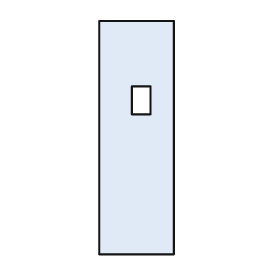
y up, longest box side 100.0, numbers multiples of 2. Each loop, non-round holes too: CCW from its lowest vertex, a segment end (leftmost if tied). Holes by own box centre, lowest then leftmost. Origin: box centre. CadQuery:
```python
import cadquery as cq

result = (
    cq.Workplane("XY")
    .moveTo(-16.0, -50.0)
    .lineTo(16.0, -50.0)
    .lineTo(16.0, 50.0)
    .lineTo(-16.0, 50.0)
    .close()
    .moveTo(-2.0, 10.0)
    .lineTo(6.0, 10.0)
    .lineTo(6.0, 22.0)
    .lineTo(-2.0, 22.0)
    .close()
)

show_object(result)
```